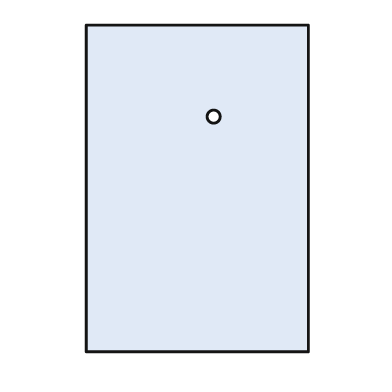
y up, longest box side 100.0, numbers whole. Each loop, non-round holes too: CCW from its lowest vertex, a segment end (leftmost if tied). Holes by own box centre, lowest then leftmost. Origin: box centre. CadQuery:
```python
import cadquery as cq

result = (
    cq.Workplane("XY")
    .moveTo(-34.0, -50.0)
    .lineTo(34.0, -50.0)
    .lineTo(34.0, 50.0)
    .lineTo(-34.0, 50.0)
    .close()
    .moveTo(5.0, 22.0)
    .circle(2.0)
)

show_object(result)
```